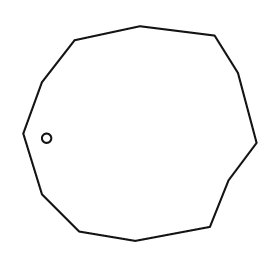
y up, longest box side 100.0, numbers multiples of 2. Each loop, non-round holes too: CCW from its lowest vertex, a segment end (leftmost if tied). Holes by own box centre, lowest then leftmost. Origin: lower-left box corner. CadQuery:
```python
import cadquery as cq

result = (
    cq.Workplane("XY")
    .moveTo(48.0, 0.0)
    .lineTo(80.0, 6.0)
    .lineTo(88.0, 26.0)
    .lineTo(100.0, 42.0)
    .lineTo(92.0, 72.0)
    .lineTo(82.0, 88.0)
    .lineTo(50.0, 92.0)
    .lineTo(22.0, 86.0)
    .lineTo(8.0, 68.0)
    .lineTo(0.0, 46.0)
    .lineTo(8.0, 20.0)
    .lineTo(24.0, 4.0)
    .close()
    .moveTo(10.0, 44.0)
    .circle(2.0)
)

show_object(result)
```